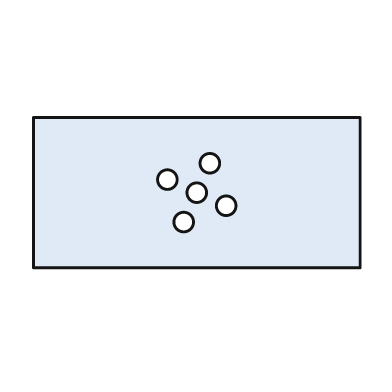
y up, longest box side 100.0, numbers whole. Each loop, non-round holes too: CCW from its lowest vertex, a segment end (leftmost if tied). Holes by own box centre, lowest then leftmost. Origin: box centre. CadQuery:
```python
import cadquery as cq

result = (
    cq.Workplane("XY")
    .moveTo(-50.0, -23.0)
    .lineTo(50.0, -23.0)
    .lineTo(50.0, 23.0)
    .lineTo(-50.0, 23.0)
    .close()
    .moveTo(-4.0, -9.0)
    .circle(3.0)
    .moveTo(9.0, -4.0)
    .circle(3.0)
    .moveTo(0.0, 0.0)
    .circle(3.0)
    .moveTo(-9.0, 4.0)
    .circle(3.0)
    .moveTo(4.0, 9.0)
    .circle(3.0)
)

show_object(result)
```